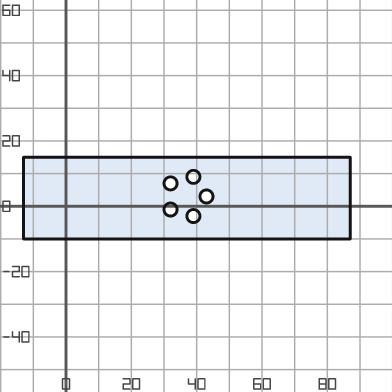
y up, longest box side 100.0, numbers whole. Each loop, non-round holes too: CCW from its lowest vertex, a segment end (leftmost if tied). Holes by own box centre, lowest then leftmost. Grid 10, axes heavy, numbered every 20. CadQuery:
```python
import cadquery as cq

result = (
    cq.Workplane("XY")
    .moveTo(-13.0, -10.0)
    .lineTo(87.0, -10.0)
    .lineTo(87.0, 15.0)
    .lineTo(-13.0, 15.0)
    .close()
    .moveTo(39.0, -3.0)
    .circle(2.0)
    .moveTo(32.0, -1.0)
    .circle(2.0)
    .moveTo(43.0, 3.0)
    .circle(2.0)
    .moveTo(32.0, 7.0)
    .circle(2.0)
    .moveTo(39.0, 9.0)
    .circle(2.0)
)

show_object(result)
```